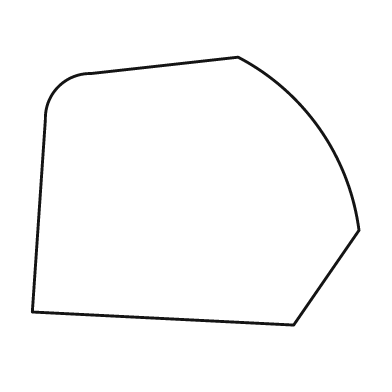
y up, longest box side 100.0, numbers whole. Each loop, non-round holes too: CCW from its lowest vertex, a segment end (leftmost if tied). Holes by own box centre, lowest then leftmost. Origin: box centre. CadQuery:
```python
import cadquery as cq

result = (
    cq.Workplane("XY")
    .moveTo(30.0, -41.0)
    .lineTo(50.0, -12.0)
    .threePointArc((38.0, 19.0), (13.0, 41.0))
    .lineTo(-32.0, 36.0)
    .threePointArc((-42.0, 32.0), (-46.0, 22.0))
    .lineTo(-50.0, -37.0)
    .close()
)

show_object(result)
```